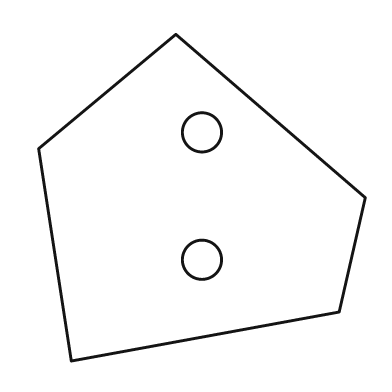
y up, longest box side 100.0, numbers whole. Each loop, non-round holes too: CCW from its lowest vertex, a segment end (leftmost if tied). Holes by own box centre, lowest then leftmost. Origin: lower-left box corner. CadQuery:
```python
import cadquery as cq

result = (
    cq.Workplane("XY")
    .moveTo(10.0, 0.0)
    .lineTo(92.0, 15.0)
    .lineTo(100.0, 50.0)
    .lineTo(42.0, 100.0)
    .lineTo(0.0, 65.0)
    .close()
    .moveTo(50.0, 31.0)
    .circle(6.0)
    .moveTo(50.0, 70.0)
    .circle(6.0)
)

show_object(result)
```